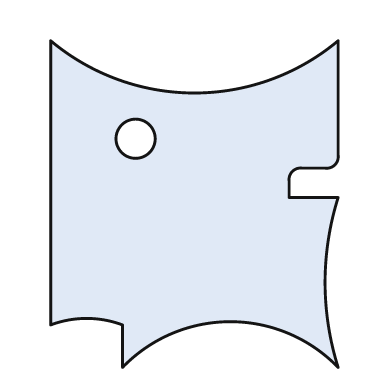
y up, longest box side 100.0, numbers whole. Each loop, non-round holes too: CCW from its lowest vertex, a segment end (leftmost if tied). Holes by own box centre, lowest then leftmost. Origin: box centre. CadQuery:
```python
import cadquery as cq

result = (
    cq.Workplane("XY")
    .moveTo(-22.0, -50.0)
    .threePointArc((11.0, -36.0), (44.0, -50.0))
    .threePointArc((40.0, -24.0), (44.0, 2.0))
    .lineTo(29.0, 2.0)
    .lineTo(29.0, 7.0)
    .threePointArc((30.0, 10.0), (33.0, 11.0))
    .lineTo(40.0, 11.0)
    .threePointArc((43.0, 12.0), (44.0, 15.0))
    .lineTo(44.0, 50.0)
    .threePointArc((0.0, 34.0), (-44.0, 50.0))
    .lineTo(-44.0, -37.0)
    .threePointArc((-33.0, -35.0), (-22.0, -37.0))
    .close()
    .moveTo(-18.0, 20.0)
    .circle(6.0)
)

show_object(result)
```